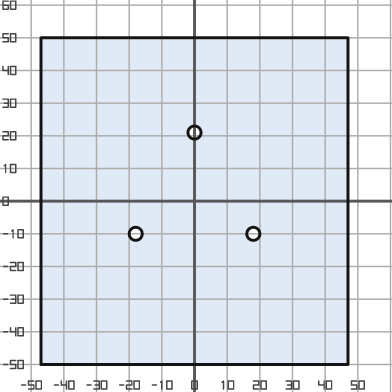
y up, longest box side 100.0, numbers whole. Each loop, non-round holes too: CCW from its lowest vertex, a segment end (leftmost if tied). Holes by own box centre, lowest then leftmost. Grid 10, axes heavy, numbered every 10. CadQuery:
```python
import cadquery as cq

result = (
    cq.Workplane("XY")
    .moveTo(-47.0, -50.0)
    .lineTo(47.0, -50.0)
    .lineTo(47.0, 50.0)
    .lineTo(-47.0, 50.0)
    .close()
    .moveTo(-18.0, -10.0)
    .circle(2.0)
    .moveTo(18.0, -10.0)
    .circle(2.0)
    .moveTo(0.0, 21.0)
    .circle(2.0)
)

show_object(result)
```